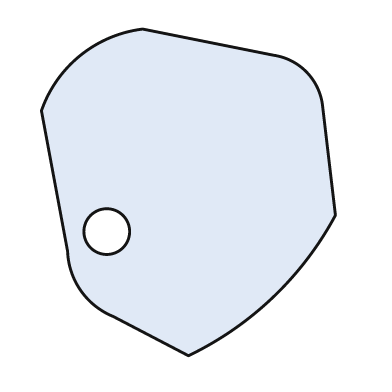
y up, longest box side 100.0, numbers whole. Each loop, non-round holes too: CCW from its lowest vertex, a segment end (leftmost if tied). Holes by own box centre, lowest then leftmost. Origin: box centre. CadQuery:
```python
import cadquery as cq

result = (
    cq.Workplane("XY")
    .moveTo(0.0, -50.0)
    .threePointArc((26.0, -32.0), (45.0, -7.0))
    .lineTo(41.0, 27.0)
    .threePointArc((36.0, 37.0), (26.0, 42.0))
    .lineTo(-14.0, 50.0)
    .threePointArc((-33.0, 42.0), (-45.0, 25.0))
    .lineTo(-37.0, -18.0)
    .threePointArc((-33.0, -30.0), (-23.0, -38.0))
    .close()
    .moveTo(-25.0, -12.0)
    .circle(7.0)
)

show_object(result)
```